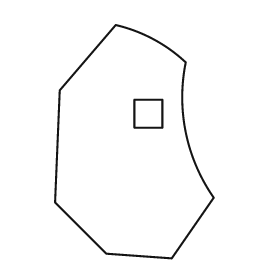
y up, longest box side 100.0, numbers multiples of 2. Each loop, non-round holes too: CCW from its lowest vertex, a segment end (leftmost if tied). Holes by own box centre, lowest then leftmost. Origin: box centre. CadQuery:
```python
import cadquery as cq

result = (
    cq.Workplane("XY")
    .moveTo(16.0, -50.0)
    .lineTo(34.0, -24.0)
    .threePointArc((22.0, 4.0), (22.0, 34.0))
    .threePointArc((8.0, 44.0), (-8.0, 50.0))
    .lineTo(-32.0, 22.0)
    .lineTo(-34.0, -26.0)
    .lineTo(-12.0, -48.0)
    .close()
    .moveTo(0.0, 6.0)
    .lineTo(12.0, 6.0)
    .lineTo(12.0, 18.0)
    .lineTo(0.0, 18.0)
    .close()
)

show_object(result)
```